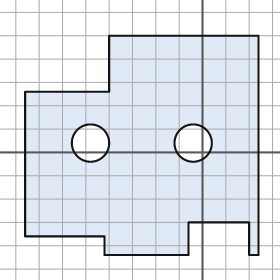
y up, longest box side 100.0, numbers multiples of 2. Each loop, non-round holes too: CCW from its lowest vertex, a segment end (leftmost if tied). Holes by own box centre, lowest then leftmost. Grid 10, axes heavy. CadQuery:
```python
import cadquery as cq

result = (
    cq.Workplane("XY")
    .moveTo(-42.0, -44.0)
    .lineTo(-6.0, -44.0)
    .lineTo(-6.0, -30.0)
    .lineTo(20.0, -30.0)
    .lineTo(20.0, -44.0)
    .lineTo(24.0, -44.0)
    .lineTo(24.0, 50.0)
    .lineTo(-40.0, 50.0)
    .lineTo(-40.0, 26.0)
    .lineTo(-76.0, 26.0)
    .lineTo(-76.0, -36.0)
    .lineTo(-42.0, -36.0)
    .close()
    .moveTo(-48.0, 4.0)
    .circle(8.0)
    .moveTo(-4.0, 4.0)
    .circle(8.0)
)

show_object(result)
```